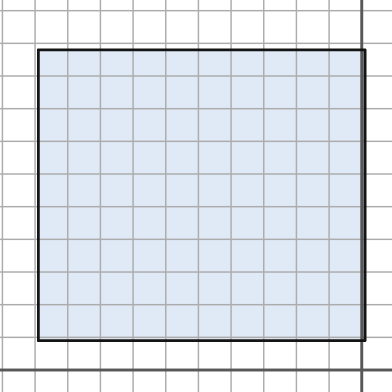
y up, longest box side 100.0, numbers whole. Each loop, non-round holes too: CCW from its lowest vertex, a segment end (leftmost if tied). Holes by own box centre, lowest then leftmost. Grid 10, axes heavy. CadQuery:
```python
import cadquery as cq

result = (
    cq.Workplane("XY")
    .moveTo(-99.0, 9.0)
    .lineTo(1.0, 9.0)
    .lineTo(1.0, 98.0)
    .lineTo(-99.0, 98.0)
    .close()
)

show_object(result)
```